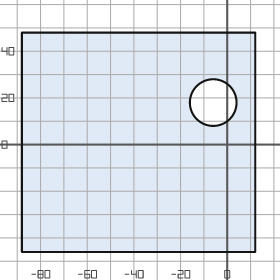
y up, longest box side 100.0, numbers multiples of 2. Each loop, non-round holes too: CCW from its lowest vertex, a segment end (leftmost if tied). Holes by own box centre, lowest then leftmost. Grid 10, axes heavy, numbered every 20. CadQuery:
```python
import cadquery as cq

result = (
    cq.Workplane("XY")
    .moveTo(-88.0, -46.0)
    .lineTo(12.0, -46.0)
    .lineTo(12.0, 48.0)
    .lineTo(-88.0, 48.0)
    .close()
    .moveTo(-6.0, 18.0)
    .circle(10.0)
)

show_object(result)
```